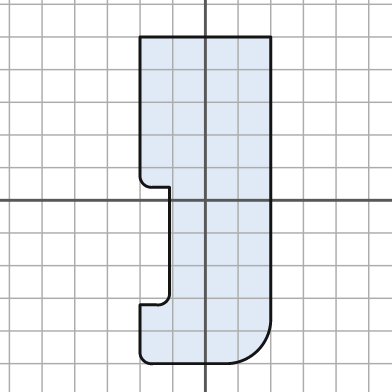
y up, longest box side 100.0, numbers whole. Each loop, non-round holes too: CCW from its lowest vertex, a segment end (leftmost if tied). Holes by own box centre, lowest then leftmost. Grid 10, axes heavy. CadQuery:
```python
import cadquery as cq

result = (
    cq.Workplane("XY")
    .moveTo(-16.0, -50.0)
    .lineTo(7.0, -50.0)
    .threePointArc((16.0, -46.0), (20.0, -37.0))
    .lineTo(20.0, 50.0)
    .lineTo(-20.0, 50.0)
    .lineTo(-20.0, 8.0)
    .threePointArc((-19.0, 5.0), (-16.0, 4.0))
    .lineTo(-11.0, 4.0)
    .lineTo(-11.0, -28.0)
    .threePointArc((-12.0, -31.0), (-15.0, -32.0))
    .lineTo(-20.0, -32.0)
    .lineTo(-20.0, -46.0)
    .threePointArc((-19.0, -49.0), (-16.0, -50.0))
    .close()
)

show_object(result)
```